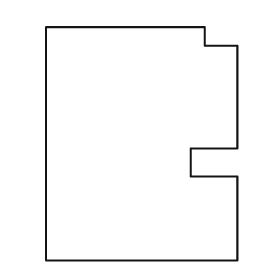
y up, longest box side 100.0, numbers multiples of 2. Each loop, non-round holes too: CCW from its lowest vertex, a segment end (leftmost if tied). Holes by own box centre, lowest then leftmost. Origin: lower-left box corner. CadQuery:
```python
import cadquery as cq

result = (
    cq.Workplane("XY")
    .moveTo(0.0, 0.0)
    .lineTo(82.0, 0.0)
    .lineTo(82.0, 36.0)
    .lineTo(62.0, 36.0)
    .lineTo(62.0, 48.0)
    .lineTo(82.0, 48.0)
    .lineTo(82.0, 92.0)
    .lineTo(68.0, 92.0)
    .lineTo(68.0, 100.0)
    .lineTo(0.0, 100.0)
    .close()
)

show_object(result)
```